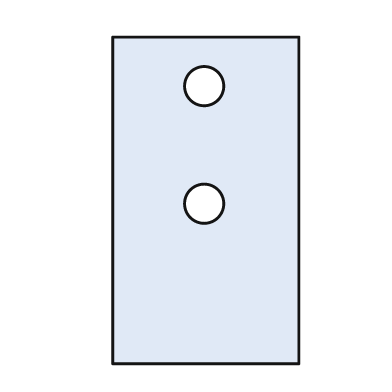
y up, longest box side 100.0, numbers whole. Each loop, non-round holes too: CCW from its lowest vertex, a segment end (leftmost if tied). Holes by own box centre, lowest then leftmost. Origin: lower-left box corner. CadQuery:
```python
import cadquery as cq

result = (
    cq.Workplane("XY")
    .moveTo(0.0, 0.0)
    .lineTo(57.0, 0.0)
    .lineTo(57.0, 100.0)
    .lineTo(0.0, 100.0)
    .close()
    .moveTo(28.0, 49.0)
    .circle(6.0)
    .moveTo(28.0, 85.0)
    .circle(6.0)
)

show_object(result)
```